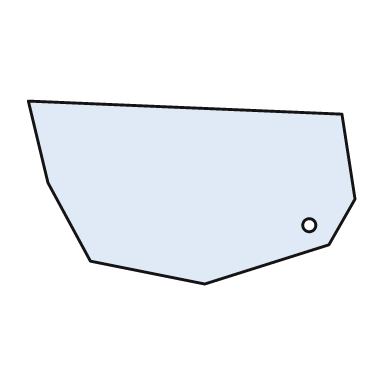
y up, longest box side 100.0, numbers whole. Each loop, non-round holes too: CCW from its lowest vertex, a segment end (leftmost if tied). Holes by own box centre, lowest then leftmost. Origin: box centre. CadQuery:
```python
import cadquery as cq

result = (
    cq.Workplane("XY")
    .moveTo(4.0, -28.0)
    .lineTo(42.0, -16.0)
    .lineTo(50.0, -2.0)
    .lineTo(46.0, 24.0)
    .lineTo(-50.0, 28.0)
    .lineTo(-44.0, 3.0)
    .lineTo(-31.0, -21.0)
    .close()
    .moveTo(36.0, -10.0)
    .circle(2.0)
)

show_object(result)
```